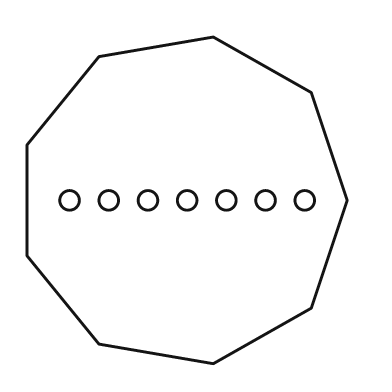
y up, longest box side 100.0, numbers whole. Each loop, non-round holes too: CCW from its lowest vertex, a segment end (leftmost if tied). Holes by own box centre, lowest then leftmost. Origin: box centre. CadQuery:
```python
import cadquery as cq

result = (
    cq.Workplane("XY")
    .moveTo(8.0, -50.0)
    .lineTo(38.0, -33.0)
    .lineTo(49.0, 0.0)
    .lineTo(38.0, 33.0)
    .lineTo(8.0, 50.0)
    .lineTo(-27.0, 44.0)
    .lineTo(-49.0, 17.0)
    .lineTo(-49.0, -17.0)
    .lineTo(-27.0, -44.0)
    .close()
    .moveTo(-36.0, 0.0)
    .circle(3.0)
    .moveTo(-24.0, 0.0)
    .circle(3.0)
    .moveTo(-12.0, 0.0)
    .circle(3.0)
    .moveTo(0.0, 0.0)
    .circle(3.0)
    .moveTo(12.0, 0.0)
    .circle(3.0)
    .moveTo(24.0, 0.0)
    .circle(3.0)
    .moveTo(36.0, 0.0)
    .circle(3.0)
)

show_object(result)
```